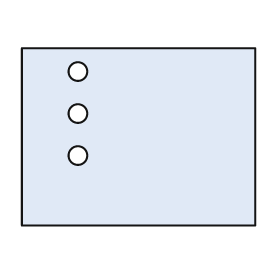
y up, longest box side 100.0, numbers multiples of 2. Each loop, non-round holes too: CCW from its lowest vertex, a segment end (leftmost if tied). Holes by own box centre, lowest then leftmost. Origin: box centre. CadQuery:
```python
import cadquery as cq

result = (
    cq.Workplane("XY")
    .moveTo(-50.0, -38.0)
    .lineTo(50.0, -38.0)
    .lineTo(50.0, 38.0)
    .lineTo(-50.0, 38.0)
    .close()
    .moveTo(-26.0, -8.0)
    .circle(4.0)
    .moveTo(-26.0, 10.0)
    .circle(4.0)
    .moveTo(-26.0, 28.0)
    .circle(4.0)
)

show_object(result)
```